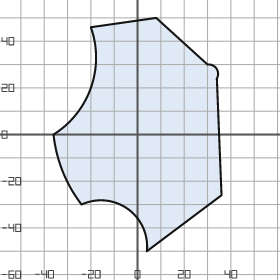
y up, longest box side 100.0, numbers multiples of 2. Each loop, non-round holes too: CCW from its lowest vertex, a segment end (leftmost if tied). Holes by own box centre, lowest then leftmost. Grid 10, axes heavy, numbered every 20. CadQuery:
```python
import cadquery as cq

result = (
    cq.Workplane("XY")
    .moveTo(4.0, -50.0)
    .lineTo(36.0, -26.0)
    .lineTo(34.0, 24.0)
    .threePointArc((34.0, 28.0), (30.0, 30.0))
    .lineTo(8.0, 50.0)
    .lineTo(-20.0, 46.0)
    .threePointArc((-20.0, 20.0), (-36.0, 0.0))
    .threePointArc((-32.0, -16.0), (-24.0, -30.0))
    .threePointArc((-4.0, -32.0), (4.0, -50.0))
    .close()
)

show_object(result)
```